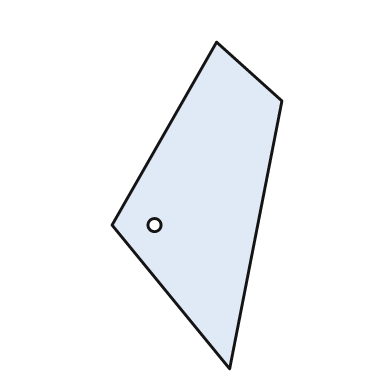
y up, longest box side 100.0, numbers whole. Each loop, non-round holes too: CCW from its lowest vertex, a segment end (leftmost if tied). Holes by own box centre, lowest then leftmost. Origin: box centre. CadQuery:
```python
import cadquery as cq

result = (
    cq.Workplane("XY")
    .moveTo(10.0, -50.0)
    .lineTo(26.0, 32.0)
    .lineTo(6.0, 50.0)
    .lineTo(-26.0, -6.0)
    .close()
    .moveTo(-13.0, -6.0)
    .circle(2.0)
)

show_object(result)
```